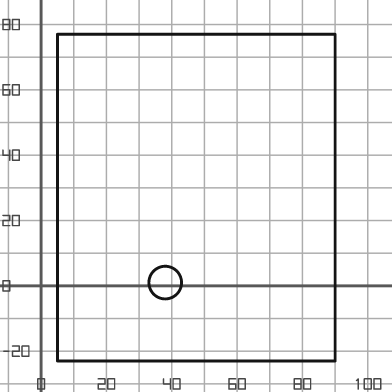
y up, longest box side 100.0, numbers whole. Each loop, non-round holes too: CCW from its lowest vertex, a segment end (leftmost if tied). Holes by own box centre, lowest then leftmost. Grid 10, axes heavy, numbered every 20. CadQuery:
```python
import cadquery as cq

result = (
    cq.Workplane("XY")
    .moveTo(5.0, -23.0)
    .lineTo(90.0, -23.0)
    .lineTo(90.0, 77.0)
    .lineTo(5.0, 77.0)
    .close()
    .moveTo(38.0, 1.0)
    .circle(5.0)
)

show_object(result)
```